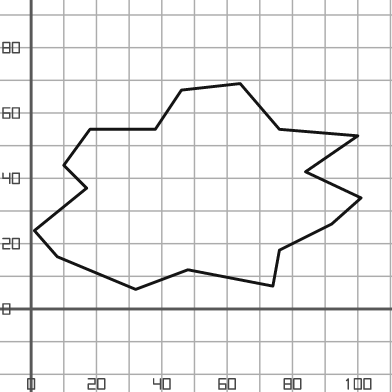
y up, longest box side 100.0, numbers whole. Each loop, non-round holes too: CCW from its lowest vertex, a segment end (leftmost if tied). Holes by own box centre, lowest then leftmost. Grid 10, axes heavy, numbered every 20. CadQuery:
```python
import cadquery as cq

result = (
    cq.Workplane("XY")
    .moveTo(32.0, 6.0)
    .lineTo(48.0, 12.0)
    .lineTo(74.0, 7.0)
    .lineTo(76.0, 18.0)
    .lineTo(92.0, 26.0)
    .lineTo(101.0, 34.0)
    .lineTo(84.0, 42.0)
    .lineTo(100.0, 53.0)
    .lineTo(76.0, 55.0)
    .lineTo(64.0, 69.0)
    .lineTo(46.0, 67.0)
    .lineTo(38.0, 55.0)
    .lineTo(18.0, 55.0)
    .lineTo(10.0, 44.0)
    .lineTo(17.0, 37.0)
    .lineTo(1.0, 24.0)
    .lineTo(8.0, 16.0)
    .close()
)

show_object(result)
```